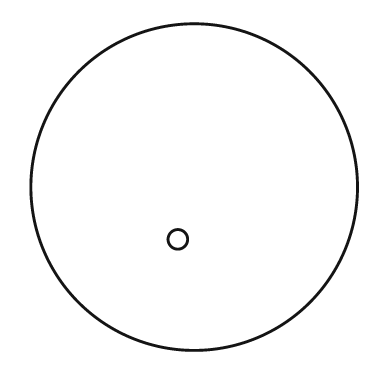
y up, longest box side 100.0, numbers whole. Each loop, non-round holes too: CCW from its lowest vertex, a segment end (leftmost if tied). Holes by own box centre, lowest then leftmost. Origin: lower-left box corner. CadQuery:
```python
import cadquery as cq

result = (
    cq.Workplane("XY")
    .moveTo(50.0, 50.0)
    .circle(50.0)
    .moveTo(45.0, 34.0)
    .circle(3.0)
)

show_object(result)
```